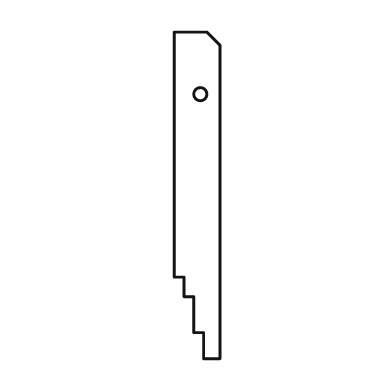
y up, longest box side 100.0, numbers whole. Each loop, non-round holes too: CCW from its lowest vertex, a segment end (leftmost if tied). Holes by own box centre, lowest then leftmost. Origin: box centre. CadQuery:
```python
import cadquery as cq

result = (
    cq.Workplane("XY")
    .moveTo(2.0, -50.0)
    .lineTo(7.0, -50.0)
    .lineTo(7.0, 46.0)
    .lineTo(3.0, 50.0)
    .lineTo(-7.0, 50.0)
    .lineTo(-7.0, -25.0)
    .lineTo(-4.0, -25.0)
    .lineTo(-4.0, -31.0)
    .lineTo(-1.0, -31.0)
    .lineTo(-1.0, -42.0)
    .lineTo(2.0, -42.0)
    .close()
    .moveTo(1.0, 31.0)
    .circle(2.0)
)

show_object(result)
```